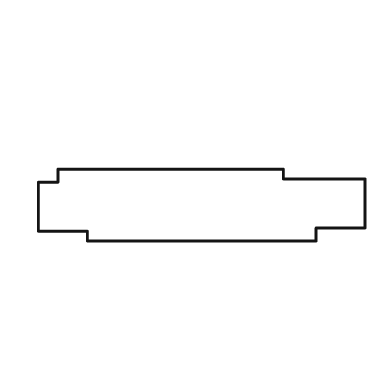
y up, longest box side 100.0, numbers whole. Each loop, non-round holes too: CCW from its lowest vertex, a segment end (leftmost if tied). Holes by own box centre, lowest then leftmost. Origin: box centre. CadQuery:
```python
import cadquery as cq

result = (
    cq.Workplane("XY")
    .moveTo(-35.0, -11.0)
    .lineTo(35.0, -11.0)
    .lineTo(35.0, -7.0)
    .lineTo(50.0, -7.0)
    .lineTo(50.0, 8.0)
    .lineTo(25.0, 8.0)
    .lineTo(25.0, 11.0)
    .lineTo(-44.0, 11.0)
    .lineTo(-44.0, 7.0)
    .lineTo(-50.0, 7.0)
    .lineTo(-50.0, -8.0)
    .lineTo(-35.0, -8.0)
    .close()
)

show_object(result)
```